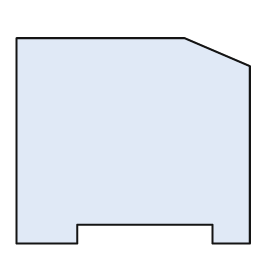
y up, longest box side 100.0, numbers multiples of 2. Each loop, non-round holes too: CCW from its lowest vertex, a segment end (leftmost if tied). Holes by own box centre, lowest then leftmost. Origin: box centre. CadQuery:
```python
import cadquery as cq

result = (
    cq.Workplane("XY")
    .moveTo(-50.0, -44.0)
    .lineTo(-24.0, -44.0)
    .lineTo(-24.0, -36.0)
    .lineTo(34.0, -36.0)
    .lineTo(34.0, -44.0)
    .lineTo(50.0, -44.0)
    .lineTo(50.0, 32.0)
    .lineTo(22.0, 44.0)
    .lineTo(-50.0, 44.0)
    .close()
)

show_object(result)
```